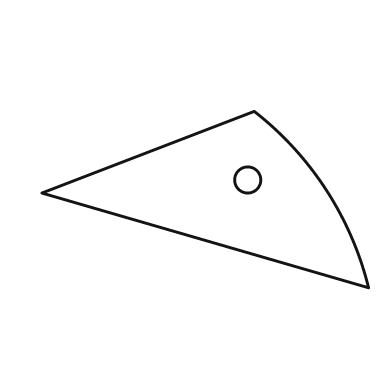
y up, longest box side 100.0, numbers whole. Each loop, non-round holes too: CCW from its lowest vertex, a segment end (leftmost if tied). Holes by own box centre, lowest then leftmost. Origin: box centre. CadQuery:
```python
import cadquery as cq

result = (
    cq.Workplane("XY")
    .moveTo(50.0, -27.0)
    .threePointArc((37.0, 3.0), (15.0, 27.0))
    .lineTo(-50.0, 2.0)
    .close()
    .moveTo(13.0, 6.0)
    .circle(4.0)
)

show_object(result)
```